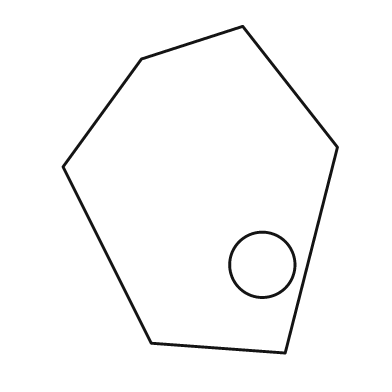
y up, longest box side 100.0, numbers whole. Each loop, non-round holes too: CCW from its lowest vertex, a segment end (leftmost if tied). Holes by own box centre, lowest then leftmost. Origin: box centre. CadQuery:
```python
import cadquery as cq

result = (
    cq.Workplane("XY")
    .moveTo(26.0, -50.0)
    .lineTo(42.0, 13.0)
    .lineTo(13.0, 50.0)
    .lineTo(-18.0, 40.0)
    .lineTo(-42.0, 7.0)
    .lineTo(-15.0, -47.0)
    .close()
    .moveTo(19.0, -23.0)
    .circle(10.0)
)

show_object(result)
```